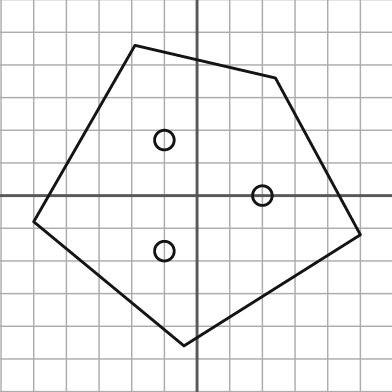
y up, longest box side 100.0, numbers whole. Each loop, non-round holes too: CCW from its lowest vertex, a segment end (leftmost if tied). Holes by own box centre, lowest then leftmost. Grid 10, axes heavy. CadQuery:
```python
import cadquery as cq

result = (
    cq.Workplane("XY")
    .moveTo(-4.0, -46.0)
    .lineTo(50.0, -12.0)
    .lineTo(24.0, 36.0)
    .lineTo(-19.0, 46.0)
    .lineTo(-50.0, -8.0)
    .close()
    .moveTo(-10.0, -17.0)
    .circle(3.0)
    .moveTo(20.0, 0.0)
    .circle(3.0)
    .moveTo(-10.0, 17.0)
    .circle(3.0)
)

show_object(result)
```